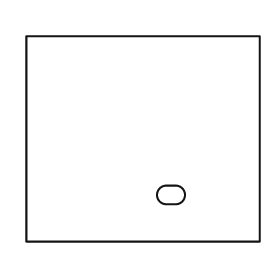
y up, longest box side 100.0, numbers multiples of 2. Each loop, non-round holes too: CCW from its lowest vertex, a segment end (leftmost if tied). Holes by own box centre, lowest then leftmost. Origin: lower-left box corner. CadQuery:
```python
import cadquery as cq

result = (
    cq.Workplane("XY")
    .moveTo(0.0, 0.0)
    .lineTo(100.0, 0.0)
    .lineTo(100.0, 88.0)
    .lineTo(0.0, 88.0)
    .close()
    .moveTo(60.0, 16.0)
    .lineTo(64.0, 16.0)
    .threePointArc((68.0, 20.0), (64.0, 24.0))
    .lineTo(60.0, 24.0)
    .threePointArc((56.0, 20.0), (60.0, 16.0))
    .close()
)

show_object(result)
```